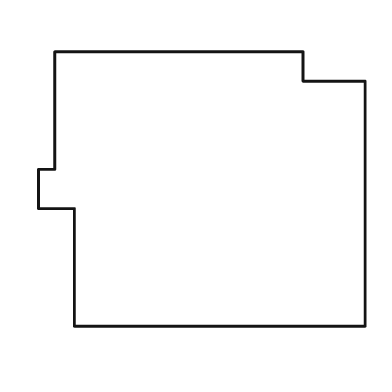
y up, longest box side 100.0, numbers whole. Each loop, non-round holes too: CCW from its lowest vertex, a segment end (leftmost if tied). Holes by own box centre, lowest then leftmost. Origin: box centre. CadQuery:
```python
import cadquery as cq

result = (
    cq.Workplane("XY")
    .moveTo(-39.0, -42.0)
    .lineTo(50.0, -42.0)
    .lineTo(50.0, 33.0)
    .lineTo(31.0, 33.0)
    .lineTo(31.0, 42.0)
    .lineTo(-45.0, 42.0)
    .lineTo(-45.0, 6.0)
    .lineTo(-50.0, 6.0)
    .lineTo(-50.0, -6.0)
    .lineTo(-39.0, -6.0)
    .close()
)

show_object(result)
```